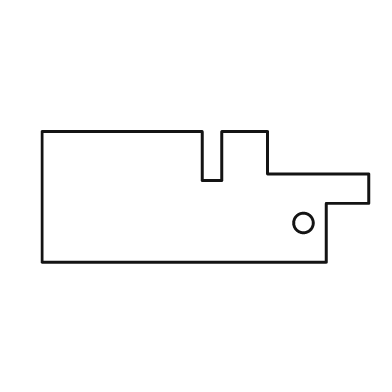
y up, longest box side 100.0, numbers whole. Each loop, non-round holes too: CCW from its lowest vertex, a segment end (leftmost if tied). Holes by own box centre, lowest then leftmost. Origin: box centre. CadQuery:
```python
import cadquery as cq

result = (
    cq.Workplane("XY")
    .moveTo(-50.0, -20.0)
    .lineTo(37.0, -20.0)
    .lineTo(37.0, -2.0)
    .lineTo(50.0, -2.0)
    .lineTo(50.0, 7.0)
    .lineTo(19.0, 7.0)
    .lineTo(19.0, 20.0)
    .lineTo(5.0, 20.0)
    .lineTo(5.0, 5.0)
    .lineTo(-1.0, 5.0)
    .lineTo(-1.0, 20.0)
    .lineTo(-50.0, 20.0)
    .close()
    .moveTo(30.0, -8.0)
    .circle(3.0)
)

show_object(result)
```